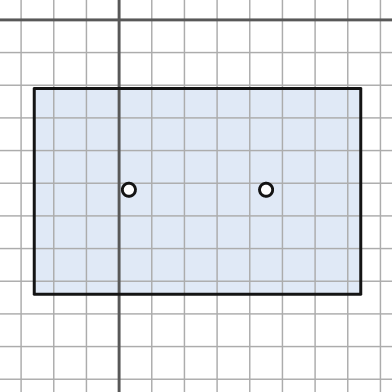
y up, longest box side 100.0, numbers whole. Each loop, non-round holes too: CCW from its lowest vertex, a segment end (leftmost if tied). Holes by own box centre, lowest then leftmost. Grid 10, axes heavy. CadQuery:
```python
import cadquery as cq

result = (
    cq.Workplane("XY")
    .moveTo(-26.0, -84.0)
    .lineTo(74.0, -84.0)
    .lineTo(74.0, -21.0)
    .lineTo(-26.0, -21.0)
    .close()
    .moveTo(3.0, -52.0)
    .circle(2.0)
    .moveTo(45.0, -52.0)
    .circle(2.0)
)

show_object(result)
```